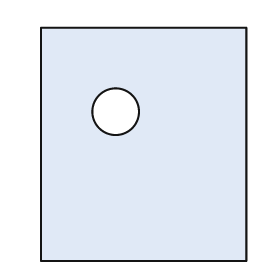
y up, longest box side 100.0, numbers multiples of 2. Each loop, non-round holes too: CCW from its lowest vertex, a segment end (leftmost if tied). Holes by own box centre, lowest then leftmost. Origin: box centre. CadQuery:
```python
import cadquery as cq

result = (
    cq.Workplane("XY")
    .moveTo(-44.0, -50.0)
    .lineTo(44.0, -50.0)
    .lineTo(44.0, 50.0)
    .lineTo(-44.0, 50.0)
    .close()
    .moveTo(-12.0, 14.0)
    .circle(10.0)
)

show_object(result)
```